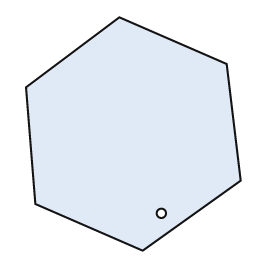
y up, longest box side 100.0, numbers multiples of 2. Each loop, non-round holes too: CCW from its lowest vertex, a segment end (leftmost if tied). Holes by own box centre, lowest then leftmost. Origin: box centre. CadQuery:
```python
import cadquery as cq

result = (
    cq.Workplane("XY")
    .moveTo(4.0, -50.0)
    .lineTo(46.0, -20.0)
    .lineTo(40.0, 30.0)
    .lineTo(-6.0, 50.0)
    .lineTo(-46.0, 20.0)
    .lineTo(-42.0, -30.0)
    .close()
    .moveTo(12.0, -34.0)
    .circle(2.0)
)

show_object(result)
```